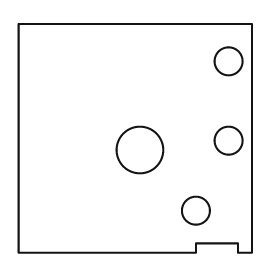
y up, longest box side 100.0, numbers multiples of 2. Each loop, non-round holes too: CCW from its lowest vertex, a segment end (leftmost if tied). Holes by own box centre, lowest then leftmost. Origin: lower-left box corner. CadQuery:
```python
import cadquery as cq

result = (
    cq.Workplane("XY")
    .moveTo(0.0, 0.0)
    .lineTo(76.0, 0.0)
    .lineTo(76.0, 4.0)
    .lineTo(94.0, 4.0)
    .lineTo(94.0, 0.0)
    .lineTo(100.0, 0.0)
    .lineTo(100.0, 98.0)
    .lineTo(0.0, 98.0)
    .close()
    .moveTo(76.0, 18.0)
    .circle(6.0)
    .moveTo(52.0, 44.0)
    .circle(10.0)
    .moveTo(90.0, 48.0)
    .circle(6.0)
    .moveTo(90.0, 82.0)
    .circle(6.0)
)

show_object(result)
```